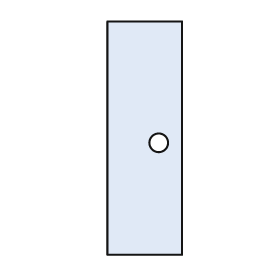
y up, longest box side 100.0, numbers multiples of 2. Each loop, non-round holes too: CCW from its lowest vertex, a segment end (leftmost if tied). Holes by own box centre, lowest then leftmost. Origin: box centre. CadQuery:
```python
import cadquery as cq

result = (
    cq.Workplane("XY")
    .moveTo(-16.0, -50.0)
    .lineTo(16.0, -50.0)
    .lineTo(16.0, 50.0)
    .lineTo(-16.0, 50.0)
    .close()
    .moveTo(6.0, -2.0)
    .circle(4.0)
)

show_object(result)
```